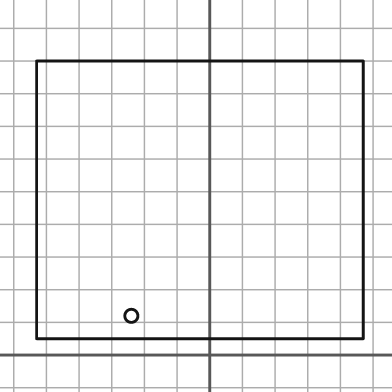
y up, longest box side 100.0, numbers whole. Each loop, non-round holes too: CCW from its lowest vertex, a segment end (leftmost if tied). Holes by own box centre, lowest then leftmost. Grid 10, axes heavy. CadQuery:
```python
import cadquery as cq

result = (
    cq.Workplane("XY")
    .moveTo(-53.0, 5.0)
    .lineTo(47.0, 5.0)
    .lineTo(47.0, 90.0)
    .lineTo(-53.0, 90.0)
    .close()
    .moveTo(-24.0, 12.0)
    .circle(2.0)
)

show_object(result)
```